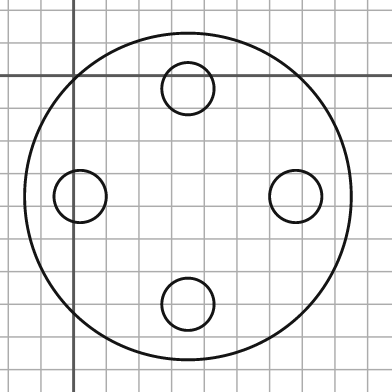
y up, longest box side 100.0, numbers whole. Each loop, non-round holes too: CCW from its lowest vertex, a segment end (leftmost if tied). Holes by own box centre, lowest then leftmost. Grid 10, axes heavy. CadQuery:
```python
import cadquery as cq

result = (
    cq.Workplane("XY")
    .moveTo(35.0, -37.0)
    .circle(50.0)
    .moveTo(35.0, -70.0)
    .circle(8.0)
    .moveTo(2.0, -37.0)
    .circle(8.0)
    .moveTo(68.0, -37.0)
    .circle(8.0)
    .moveTo(35.0, -4.0)
    .circle(8.0)
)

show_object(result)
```